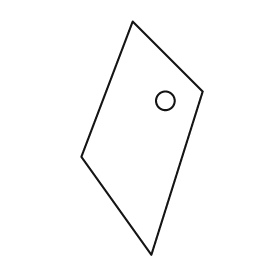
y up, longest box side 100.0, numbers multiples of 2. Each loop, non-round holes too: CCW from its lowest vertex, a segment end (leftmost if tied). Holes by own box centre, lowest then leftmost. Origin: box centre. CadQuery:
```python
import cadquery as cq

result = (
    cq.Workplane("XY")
    .moveTo(4.0, -50.0)
    .lineTo(26.0, 20.0)
    .lineTo(-4.0, 50.0)
    .lineTo(-26.0, -8.0)
    .close()
    .moveTo(10.0, 16.0)
    .circle(4.0)
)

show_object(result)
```